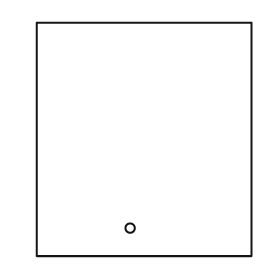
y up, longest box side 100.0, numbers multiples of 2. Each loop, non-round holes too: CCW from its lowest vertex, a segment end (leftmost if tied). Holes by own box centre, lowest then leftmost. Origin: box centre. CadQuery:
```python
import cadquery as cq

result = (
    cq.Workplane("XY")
    .moveTo(-46.0, -50.0)
    .lineTo(46.0, -50.0)
    .lineTo(46.0, 50.0)
    .lineTo(-46.0, 50.0)
    .close()
    .moveTo(-6.0, -38.0)
    .circle(2.0)
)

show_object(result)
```